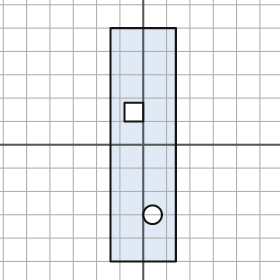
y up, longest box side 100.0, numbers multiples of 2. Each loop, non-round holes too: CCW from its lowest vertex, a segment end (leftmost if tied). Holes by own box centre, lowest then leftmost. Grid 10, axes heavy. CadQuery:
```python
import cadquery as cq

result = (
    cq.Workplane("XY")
    .moveTo(-14.0, -50.0)
    .lineTo(14.0, -50.0)
    .lineTo(14.0, 50.0)
    .lineTo(-14.0, 50.0)
    .close()
    .moveTo(4.0, -30.0)
    .circle(4.0)
    .moveTo(-8.0, 10.0)
    .lineTo(0.0, 10.0)
    .lineTo(0.0, 18.0)
    .lineTo(-8.0, 18.0)
    .close()
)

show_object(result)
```